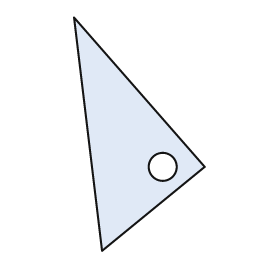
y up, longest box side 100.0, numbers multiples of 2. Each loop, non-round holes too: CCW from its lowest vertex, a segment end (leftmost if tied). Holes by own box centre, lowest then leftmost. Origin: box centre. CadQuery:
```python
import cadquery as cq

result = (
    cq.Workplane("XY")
    .moveTo(-16.0, -50.0)
    .lineTo(28.0, -14.0)
    .lineTo(-28.0, 50.0)
    .close()
    .moveTo(10.0, -14.0)
    .circle(6.0)
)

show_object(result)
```